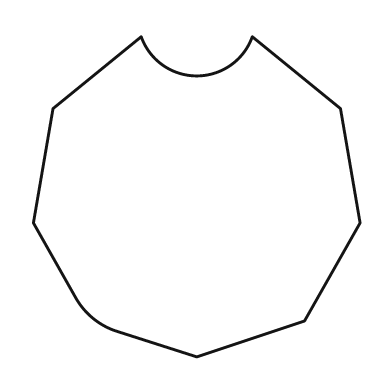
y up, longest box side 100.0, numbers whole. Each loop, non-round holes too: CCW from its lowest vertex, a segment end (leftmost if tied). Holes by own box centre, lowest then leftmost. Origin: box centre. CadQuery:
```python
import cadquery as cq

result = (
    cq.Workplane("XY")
    .moveTo(0.0, -49.0)
    .lineTo(33.0, -38.0)
    .lineTo(50.0, -8.0)
    .lineTo(44.0, 27.0)
    .lineTo(17.0, 49.0)
    .threePointArc((0.0, 37.0), (-17.0, 49.0))
    .lineTo(-44.0, 27.0)
    .lineTo(-50.0, -8.0)
    .lineTo(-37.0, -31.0)
    .threePointArc((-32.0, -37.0), (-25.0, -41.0))
    .close()
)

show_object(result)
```